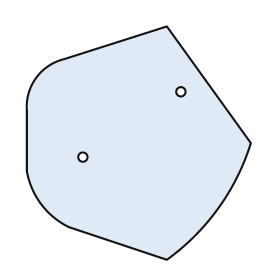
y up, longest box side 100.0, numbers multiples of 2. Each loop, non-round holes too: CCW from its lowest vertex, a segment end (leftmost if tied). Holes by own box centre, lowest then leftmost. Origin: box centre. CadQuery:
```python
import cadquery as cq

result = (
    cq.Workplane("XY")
    .moveTo(12.0, -50.0)
    .threePointArc((34.0, -28.0), (48.0, 0.0))
    .lineTo(12.0, 50.0)
    .lineTo(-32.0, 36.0)
    .threePointArc((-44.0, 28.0), (-48.0, 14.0))
    .lineTo(-48.0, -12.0)
    .threePointArc((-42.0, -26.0), (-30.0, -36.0))
    .close()
    .moveTo(-24.0, -6.0)
    .circle(2.0)
    .moveTo(18.0, 22.0)
    .circle(2.0)
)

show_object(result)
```